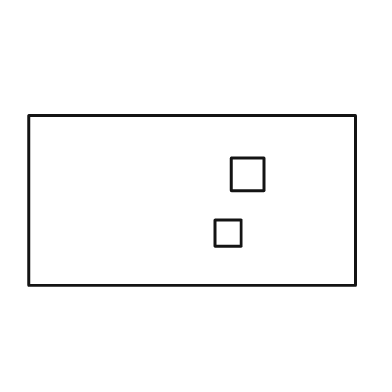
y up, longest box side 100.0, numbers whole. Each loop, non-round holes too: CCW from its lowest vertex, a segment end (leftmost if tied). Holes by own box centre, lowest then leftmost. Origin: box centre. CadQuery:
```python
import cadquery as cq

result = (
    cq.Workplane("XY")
    .moveTo(-50.0, -26.0)
    .lineTo(50.0, -26.0)
    .lineTo(50.0, 26.0)
    .lineTo(-50.0, 26.0)
    .close()
    .moveTo(7.0, -14.0)
    .lineTo(15.0, -14.0)
    .lineTo(15.0, -6.0)
    .lineTo(7.0, -6.0)
    .close()
    .moveTo(12.0, 3.0)
    .lineTo(22.0, 3.0)
    .lineTo(22.0, 13.0)
    .lineTo(12.0, 13.0)
    .close()
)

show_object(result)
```